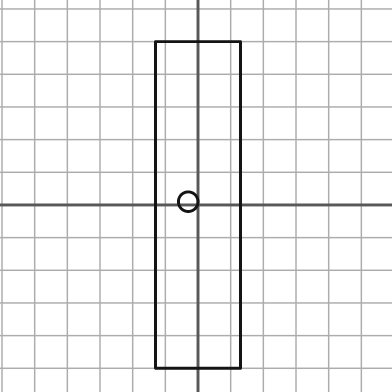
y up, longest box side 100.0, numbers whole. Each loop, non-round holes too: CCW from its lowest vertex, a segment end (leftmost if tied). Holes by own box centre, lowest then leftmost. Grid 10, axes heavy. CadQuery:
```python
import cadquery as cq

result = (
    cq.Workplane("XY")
    .moveTo(-13.0, -50.0)
    .lineTo(13.0, -50.0)
    .lineTo(13.0, 50.0)
    .lineTo(-13.0, 50.0)
    .close()
    .moveTo(-3.0, 1.0)
    .circle(3.0)
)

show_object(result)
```